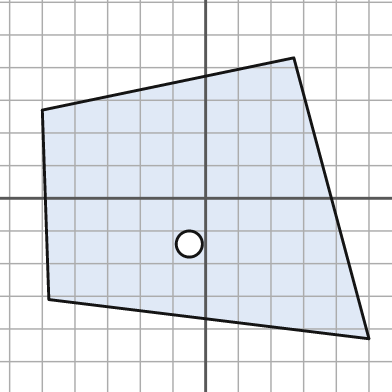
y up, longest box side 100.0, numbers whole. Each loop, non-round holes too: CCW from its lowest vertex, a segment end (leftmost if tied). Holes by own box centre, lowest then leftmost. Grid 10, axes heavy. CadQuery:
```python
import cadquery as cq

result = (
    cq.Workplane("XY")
    .moveTo(50.0, -43.0)
    .lineTo(27.0, 43.0)
    .lineTo(-50.0, 27.0)
    .lineTo(-48.0, -31.0)
    .close()
    .moveTo(-5.0, -14.0)
    .circle(4.0)
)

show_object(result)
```